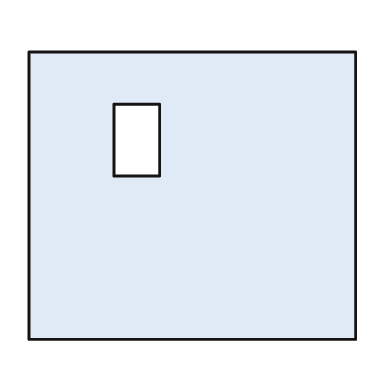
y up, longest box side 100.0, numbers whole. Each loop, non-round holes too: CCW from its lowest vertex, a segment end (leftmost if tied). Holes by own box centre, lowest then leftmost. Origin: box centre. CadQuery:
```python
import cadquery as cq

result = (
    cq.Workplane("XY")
    .moveTo(-50.0, -44.0)
    .lineTo(50.0, -44.0)
    .lineTo(50.0, 44.0)
    .lineTo(-50.0, 44.0)
    .close()
    .moveTo(-24.0, 6.0)
    .lineTo(-10.0, 6.0)
    .lineTo(-10.0, 28.0)
    .lineTo(-24.0, 28.0)
    .close()
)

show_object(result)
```